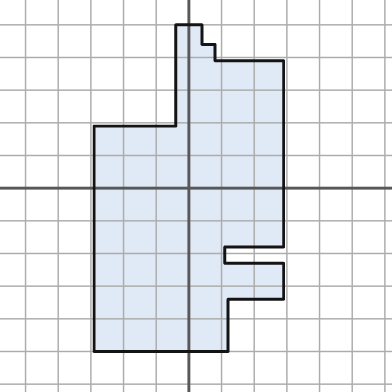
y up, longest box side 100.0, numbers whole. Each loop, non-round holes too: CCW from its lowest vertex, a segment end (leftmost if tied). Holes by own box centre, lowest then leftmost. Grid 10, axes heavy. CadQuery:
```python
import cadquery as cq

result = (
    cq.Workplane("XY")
    .moveTo(-29.0, -50.0)
    .lineTo(12.0, -50.0)
    .lineTo(12.0, -34.0)
    .lineTo(29.0, -34.0)
    .lineTo(29.0, -23.0)
    .lineTo(11.0, -23.0)
    .lineTo(11.0, -18.0)
    .lineTo(29.0, -18.0)
    .lineTo(29.0, 39.0)
    .lineTo(8.0, 39.0)
    .lineTo(8.0, 44.0)
    .lineTo(4.0, 44.0)
    .lineTo(4.0, 50.0)
    .lineTo(-4.0, 50.0)
    .lineTo(-4.0, 19.0)
    .lineTo(-29.0, 19.0)
    .close()
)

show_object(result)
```